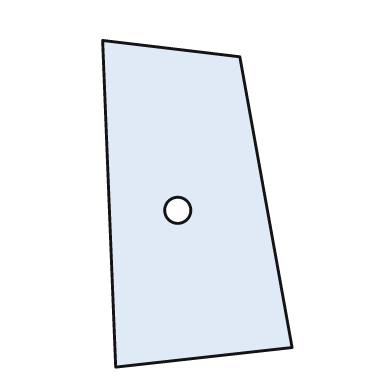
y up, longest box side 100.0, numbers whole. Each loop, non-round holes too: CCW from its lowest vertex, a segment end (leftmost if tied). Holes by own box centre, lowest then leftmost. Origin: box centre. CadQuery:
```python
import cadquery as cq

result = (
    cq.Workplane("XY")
    .moveTo(-25.0, -50.0)
    .lineTo(29.0, -44.0)
    .lineTo(13.0, 45.0)
    .lineTo(-29.0, 50.0)
    .close()
    .moveTo(-6.0, -2.0)
    .circle(4.0)
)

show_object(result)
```